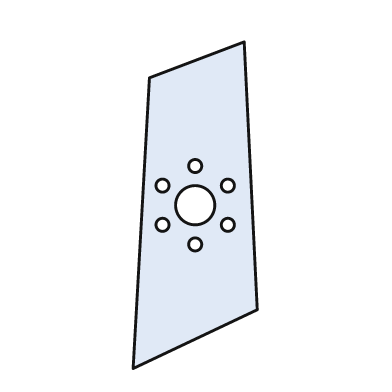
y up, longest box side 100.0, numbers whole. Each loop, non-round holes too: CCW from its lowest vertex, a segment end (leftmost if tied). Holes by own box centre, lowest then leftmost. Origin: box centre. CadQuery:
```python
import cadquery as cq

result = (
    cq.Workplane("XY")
    .moveTo(-19.0, -50.0)
    .lineTo(19.0, -32.0)
    .lineTo(15.0, 50.0)
    .lineTo(-14.0, 39.0)
    .close()
    .moveTo(0.0, -12.0)
    .circle(2.0)
    .moveTo(-10.0, -6.0)
    .circle(2.0)
    .moveTo(10.0, -6.0)
    .circle(2.0)
    .moveTo(0.0, 0.0)
    .circle(6.0)
    .moveTo(-10.0, 6.0)
    .circle(2.0)
    .moveTo(10.0, 6.0)
    .circle(2.0)
    .moveTo(0.0, 12.0)
    .circle(2.0)
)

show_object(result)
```